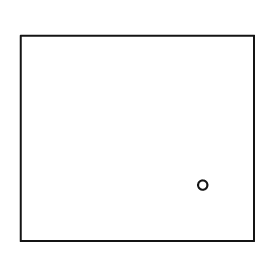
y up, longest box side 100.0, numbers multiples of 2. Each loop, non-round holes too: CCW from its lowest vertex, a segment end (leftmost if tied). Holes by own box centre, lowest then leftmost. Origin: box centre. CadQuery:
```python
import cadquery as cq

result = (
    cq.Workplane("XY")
    .moveTo(-50.0, -44.0)
    .lineTo(50.0, -44.0)
    .lineTo(50.0, 44.0)
    .lineTo(-50.0, 44.0)
    .close()
    .moveTo(28.0, -20.0)
    .circle(2.0)
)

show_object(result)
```